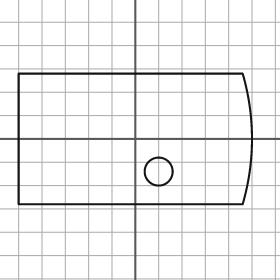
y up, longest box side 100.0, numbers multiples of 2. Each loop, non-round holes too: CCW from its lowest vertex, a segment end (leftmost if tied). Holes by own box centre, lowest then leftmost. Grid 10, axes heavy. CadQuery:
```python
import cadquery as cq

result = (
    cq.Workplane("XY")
    .moveTo(-50.0, -28.0)
    .lineTo(46.0, -28.0)
    .threePointArc((50.0, 0.0), (46.0, 28.0))
    .lineTo(-50.0, 28.0)
    .close()
    .moveTo(10.0, -14.0)
    .circle(6.0)
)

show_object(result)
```